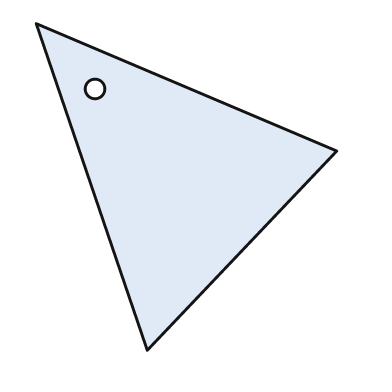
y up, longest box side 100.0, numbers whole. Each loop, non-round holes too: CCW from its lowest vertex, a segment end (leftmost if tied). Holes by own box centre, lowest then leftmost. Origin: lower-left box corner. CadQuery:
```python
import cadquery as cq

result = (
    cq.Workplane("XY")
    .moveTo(34.0, 0.0)
    .lineTo(92.0, 61.0)
    .lineTo(0.0, 100.0)
    .close()
    .moveTo(18.0, 80.0)
    .circle(3.0)
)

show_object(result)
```